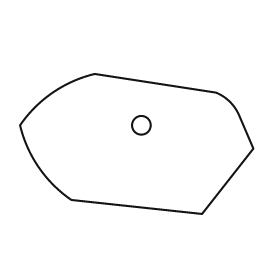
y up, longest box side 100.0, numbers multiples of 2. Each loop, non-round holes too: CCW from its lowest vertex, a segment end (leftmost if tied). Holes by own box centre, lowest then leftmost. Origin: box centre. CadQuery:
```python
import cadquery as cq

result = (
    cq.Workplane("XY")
    .moveTo(28.0, -30.0)
    .lineTo(50.0, -2.0)
    .lineTo(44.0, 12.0)
    .threePointArc((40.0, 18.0), (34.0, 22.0))
    .lineTo(-18.0, 30.0)
    .threePointArc((-36.0, 22.0), (-50.0, 8.0))
    .threePointArc((-42.0, -10.0), (-28.0, -24.0))
    .close()
    .moveTo(2.0, 8.0)
    .circle(4.0)
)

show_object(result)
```